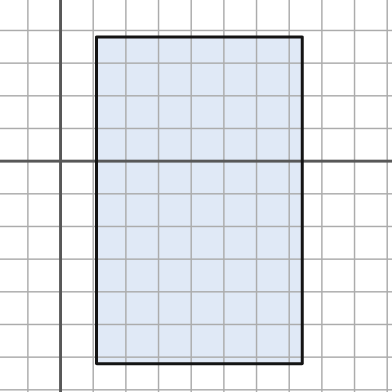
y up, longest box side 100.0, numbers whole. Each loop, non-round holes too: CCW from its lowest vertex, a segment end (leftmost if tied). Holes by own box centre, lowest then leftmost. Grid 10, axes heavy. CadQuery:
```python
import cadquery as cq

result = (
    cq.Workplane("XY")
    .moveTo(11.0, -62.0)
    .lineTo(74.0, -62.0)
    .lineTo(74.0, 38.0)
    .lineTo(11.0, 38.0)
    .close()
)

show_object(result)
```